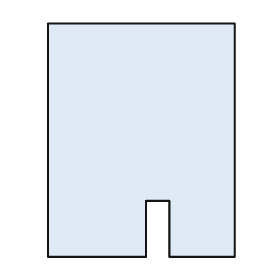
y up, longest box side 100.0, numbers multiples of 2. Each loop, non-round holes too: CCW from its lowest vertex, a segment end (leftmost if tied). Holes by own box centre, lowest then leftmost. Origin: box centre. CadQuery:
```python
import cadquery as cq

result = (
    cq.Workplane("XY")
    .moveTo(-40.0, -50.0)
    .lineTo(2.0, -50.0)
    .lineTo(2.0, -26.0)
    .lineTo(12.0, -26.0)
    .lineTo(12.0, -50.0)
    .lineTo(40.0, -50.0)
    .lineTo(40.0, 50.0)
    .lineTo(-40.0, 50.0)
    .close()
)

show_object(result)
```